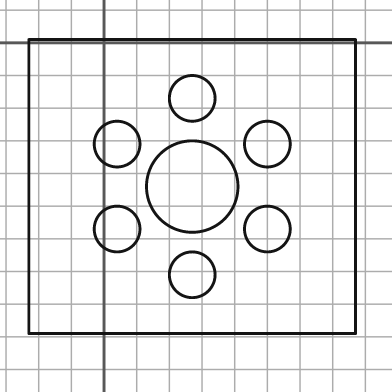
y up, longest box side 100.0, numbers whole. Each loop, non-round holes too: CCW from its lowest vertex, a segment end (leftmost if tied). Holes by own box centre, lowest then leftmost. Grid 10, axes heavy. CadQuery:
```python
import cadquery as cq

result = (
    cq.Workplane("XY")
    .moveTo(-23.0, -89.0)
    .lineTo(77.0, -89.0)
    .lineTo(77.0, 1.0)
    .lineTo(-23.0, 1.0)
    .close()
    .moveTo(27.0, -71.0)
    .circle(7.0)
    .moveTo(4.0, -57.0)
    .circle(7.0)
    .moveTo(50.0, -57.0)
    .circle(7.0)
    .moveTo(27.0, -44.0)
    .circle(14.0)
    .moveTo(4.0, -31.0)
    .circle(7.0)
    .moveTo(50.0, -31.0)
    .circle(7.0)
    .moveTo(27.0, -17.0)
    .circle(7.0)
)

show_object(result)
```